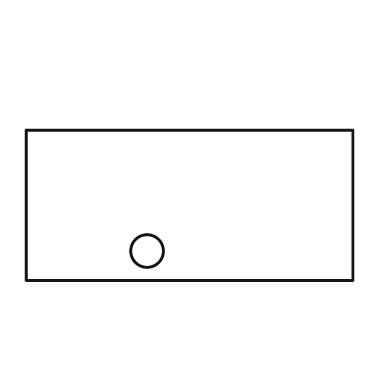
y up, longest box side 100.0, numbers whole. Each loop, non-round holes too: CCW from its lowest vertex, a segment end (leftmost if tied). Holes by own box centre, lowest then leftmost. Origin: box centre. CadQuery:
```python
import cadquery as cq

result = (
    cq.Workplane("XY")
    .moveTo(-50.0, -23.0)
    .lineTo(50.0, -23.0)
    .lineTo(50.0, 23.0)
    .lineTo(-50.0, 23.0)
    .close()
    .moveTo(-13.0, -14.0)
    .circle(5.0)
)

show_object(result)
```